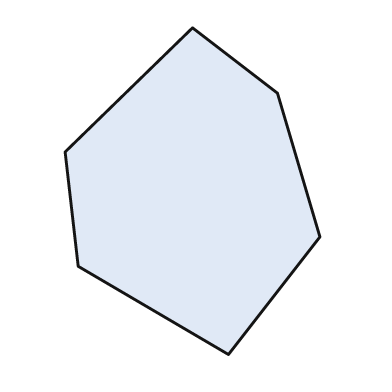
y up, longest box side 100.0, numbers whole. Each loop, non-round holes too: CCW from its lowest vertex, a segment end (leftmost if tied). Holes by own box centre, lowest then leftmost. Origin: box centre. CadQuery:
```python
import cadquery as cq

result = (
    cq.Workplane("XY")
    .moveTo(11.0, -50.0)
    .lineTo(39.0, -14.0)
    .lineTo(26.0, 30.0)
    .lineTo(0.0, 50.0)
    .lineTo(-39.0, 12.0)
    .lineTo(-35.0, -23.0)
    .close()
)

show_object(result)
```